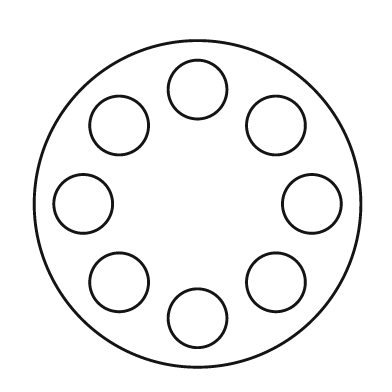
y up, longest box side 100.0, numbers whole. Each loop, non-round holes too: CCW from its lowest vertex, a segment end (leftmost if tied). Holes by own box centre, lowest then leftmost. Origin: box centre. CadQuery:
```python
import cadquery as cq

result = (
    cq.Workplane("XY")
    .moveTo(0.0, 0.0)
    .circle(50.0)
    .moveTo(0.0, -35.0)
    .circle(9.0)
    .moveTo(-24.0, -24.0)
    .circle(9.0)
    .moveTo(24.0, -24.0)
    .circle(9.0)
    .moveTo(-35.0, 0.0)
    .circle(9.0)
    .moveTo(35.0, 0.0)
    .circle(9.0)
    .moveTo(-24.0, 24.0)
    .circle(9.0)
    .moveTo(24.0, 24.0)
    .circle(9.0)
    .moveTo(0.0, 35.0)
    .circle(9.0)
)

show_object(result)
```